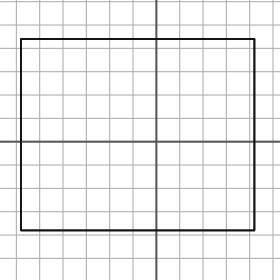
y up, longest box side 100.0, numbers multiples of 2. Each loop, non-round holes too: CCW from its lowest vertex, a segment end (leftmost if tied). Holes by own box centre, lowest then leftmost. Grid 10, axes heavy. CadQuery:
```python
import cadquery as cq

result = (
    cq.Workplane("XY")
    .moveTo(-58.0, -38.0)
    .lineTo(42.0, -38.0)
    .lineTo(42.0, 44.0)
    .lineTo(-58.0, 44.0)
    .close()
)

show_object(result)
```